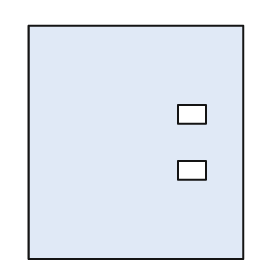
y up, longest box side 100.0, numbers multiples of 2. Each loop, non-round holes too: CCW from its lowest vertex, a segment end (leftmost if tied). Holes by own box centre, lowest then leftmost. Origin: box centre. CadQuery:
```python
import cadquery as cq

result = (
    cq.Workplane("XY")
    .moveTo(-46.0, -50.0)
    .lineTo(46.0, -50.0)
    .lineTo(46.0, 50.0)
    .lineTo(-46.0, 50.0)
    .close()
    .moveTo(18.0, -16.0)
    .lineTo(30.0, -16.0)
    .lineTo(30.0, -8.0)
    .lineTo(18.0, -8.0)
    .close()
    .moveTo(18.0, 8.0)
    .lineTo(30.0, 8.0)
    .lineTo(30.0, 16.0)
    .lineTo(18.0, 16.0)
    .close()
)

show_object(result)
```